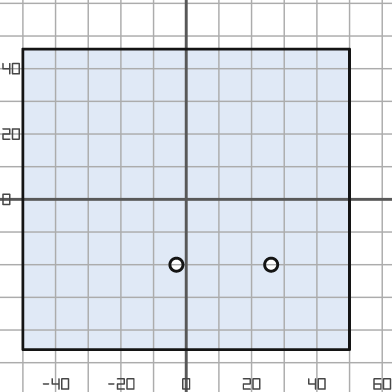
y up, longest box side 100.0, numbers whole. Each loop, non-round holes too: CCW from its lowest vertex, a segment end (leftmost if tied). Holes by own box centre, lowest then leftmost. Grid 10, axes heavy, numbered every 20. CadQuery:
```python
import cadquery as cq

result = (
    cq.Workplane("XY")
    .moveTo(-50.0, -46.0)
    .lineTo(50.0, -46.0)
    .lineTo(50.0, 46.0)
    .lineTo(-50.0, 46.0)
    .close()
    .moveTo(-3.0, -20.0)
    .circle(2.0)
    .moveTo(26.0, -20.0)
    .circle(2.0)
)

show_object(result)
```